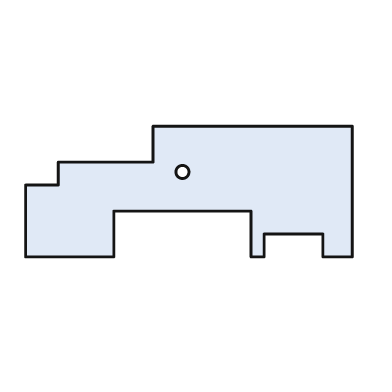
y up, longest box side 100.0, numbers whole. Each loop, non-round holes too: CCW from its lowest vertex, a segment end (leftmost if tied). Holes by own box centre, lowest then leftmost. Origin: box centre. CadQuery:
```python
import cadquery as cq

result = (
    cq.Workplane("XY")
    .moveTo(-50.0, -20.0)
    .lineTo(-23.0, -20.0)
    .lineTo(-23.0, -6.0)
    .lineTo(19.0, -6.0)
    .lineTo(19.0, -20.0)
    .lineTo(23.0, -20.0)
    .lineTo(23.0, -13.0)
    .lineTo(41.0, -13.0)
    .lineTo(41.0, -20.0)
    .lineTo(50.0, -20.0)
    .lineTo(50.0, 20.0)
    .lineTo(-11.0, 20.0)
    .lineTo(-11.0, 9.0)
    .lineTo(-40.0, 9.0)
    .lineTo(-40.0, 2.0)
    .lineTo(-50.0, 2.0)
    .close()
    .moveTo(-2.0, 6.0)
    .circle(2.0)
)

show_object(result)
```